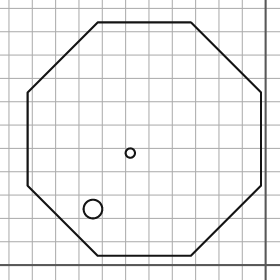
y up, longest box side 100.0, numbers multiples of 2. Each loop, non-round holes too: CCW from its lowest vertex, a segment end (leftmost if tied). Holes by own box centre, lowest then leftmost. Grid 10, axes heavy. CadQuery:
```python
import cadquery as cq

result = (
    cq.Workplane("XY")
    .moveTo(-72.0, 4.0)
    .lineTo(-32.0, 4.0)
    .lineTo(-2.0, 34.0)
    .lineTo(-2.0, 74.0)
    .lineTo(-32.0, 104.0)
    .lineTo(-72.0, 104.0)
    .lineTo(-102.0, 74.0)
    .lineTo(-102.0, 34.0)
    .close()
    .moveTo(-74.0, 24.0)
    .circle(4.0)
    .moveTo(-58.0, 48.0)
    .circle(2.0)
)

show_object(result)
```